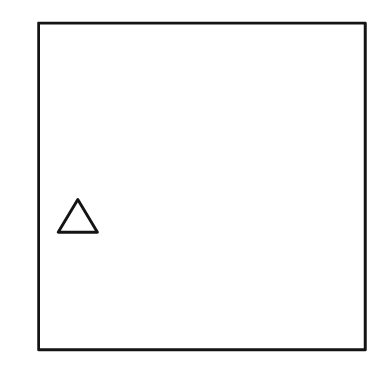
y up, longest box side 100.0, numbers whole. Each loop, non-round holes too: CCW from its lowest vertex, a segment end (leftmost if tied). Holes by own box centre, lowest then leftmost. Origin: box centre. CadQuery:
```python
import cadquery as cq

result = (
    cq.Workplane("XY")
    .moveTo(-50.0, -50.0)
    .lineTo(50.0, -50.0)
    .lineTo(50.0, 50.0)
    .lineTo(-50.0, 50.0)
    .close()
    .moveTo(-44.0, -14.0)
    .lineTo(-32.0, -14.0)
    .lineTo(-38.0, -4.0)
    .close()
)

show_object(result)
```